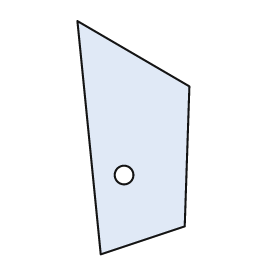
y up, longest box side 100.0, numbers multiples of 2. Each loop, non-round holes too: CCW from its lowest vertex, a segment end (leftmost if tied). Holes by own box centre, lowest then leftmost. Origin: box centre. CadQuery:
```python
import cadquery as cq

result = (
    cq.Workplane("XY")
    .moveTo(-14.0, -50.0)
    .lineTo(22.0, -38.0)
    .lineTo(24.0, 22.0)
    .lineTo(-24.0, 50.0)
    .close()
    .moveTo(-4.0, -16.0)
    .circle(4.0)
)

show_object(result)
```